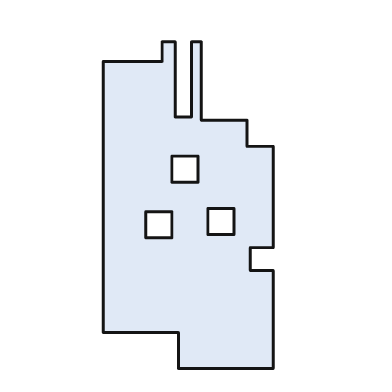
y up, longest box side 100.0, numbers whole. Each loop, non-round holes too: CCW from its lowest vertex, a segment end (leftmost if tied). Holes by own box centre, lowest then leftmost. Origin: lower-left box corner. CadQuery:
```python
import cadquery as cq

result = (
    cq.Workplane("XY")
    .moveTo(23.0, 0.0)
    .lineTo(52.0, 0.0)
    .lineTo(52.0, 30.0)
    .lineTo(45.0, 30.0)
    .lineTo(45.0, 37.0)
    .lineTo(52.0, 37.0)
    .lineTo(52.0, 68.0)
    .lineTo(44.0, 68.0)
    .lineTo(44.0, 76.0)
    .lineTo(30.0, 76.0)
    .lineTo(30.0, 100.0)
    .lineTo(27.0, 100.0)
    .lineTo(27.0, 77.0)
    .lineTo(22.0, 77.0)
    .lineTo(22.0, 100.0)
    .lineTo(18.0, 100.0)
    .lineTo(18.0, 94.0)
    .lineTo(0.0, 94.0)
    .lineTo(0.0, 11.0)
    .lineTo(23.0, 11.0)
    .close()
    .moveTo(13.0, 40.0)
    .lineTo(21.0, 40.0)
    .lineTo(21.0, 48.0)
    .lineTo(13.0, 48.0)
    .close()
    .moveTo(32.0, 41.0)
    .lineTo(40.0, 41.0)
    .lineTo(40.0, 49.0)
    .lineTo(32.0, 49.0)
    .close()
    .moveTo(21.0, 57.0)
    .lineTo(29.0, 57.0)
    .lineTo(29.0, 65.0)
    .lineTo(21.0, 65.0)
    .close()
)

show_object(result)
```